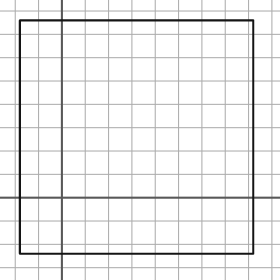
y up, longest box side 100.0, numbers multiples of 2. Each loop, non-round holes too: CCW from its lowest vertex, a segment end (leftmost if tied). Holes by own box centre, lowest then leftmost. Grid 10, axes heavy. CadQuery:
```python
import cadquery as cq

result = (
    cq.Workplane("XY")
    .moveTo(-18.0, -24.0)
    .lineTo(82.0, -24.0)
    .lineTo(82.0, 76.0)
    .lineTo(-18.0, 76.0)
    .close()
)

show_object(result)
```